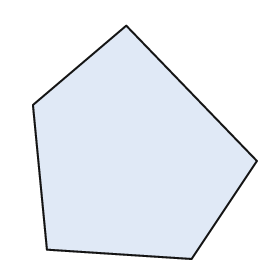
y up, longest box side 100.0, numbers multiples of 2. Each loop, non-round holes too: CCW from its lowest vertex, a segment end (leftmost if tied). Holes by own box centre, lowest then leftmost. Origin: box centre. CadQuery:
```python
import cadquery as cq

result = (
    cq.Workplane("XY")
    .moveTo(20.0, -50.0)
    .lineTo(48.0, -8.0)
    .lineTo(-8.0, 50.0)
    .lineTo(-48.0, 16.0)
    .lineTo(-42.0, -46.0)
    .close()
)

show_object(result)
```